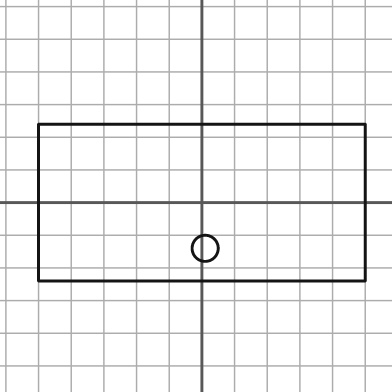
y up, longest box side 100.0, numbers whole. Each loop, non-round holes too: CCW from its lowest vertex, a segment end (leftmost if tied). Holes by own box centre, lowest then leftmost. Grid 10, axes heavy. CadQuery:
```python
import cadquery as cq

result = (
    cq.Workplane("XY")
    .moveTo(-50.0, -24.0)
    .lineTo(50.0, -24.0)
    .lineTo(50.0, 24.0)
    .lineTo(-50.0, 24.0)
    .close()
    .moveTo(1.0, -14.0)
    .circle(4.0)
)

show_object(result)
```